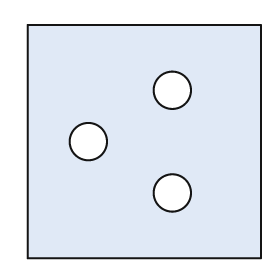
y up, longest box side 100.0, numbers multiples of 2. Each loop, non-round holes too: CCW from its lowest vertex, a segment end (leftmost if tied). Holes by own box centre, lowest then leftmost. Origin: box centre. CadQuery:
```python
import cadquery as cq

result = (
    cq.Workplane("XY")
    .moveTo(-50.0, -50.0)
    .lineTo(50.0, -50.0)
    .lineTo(50.0, 50.0)
    .lineTo(-50.0, 50.0)
    .close()
    .moveTo(12.0, -22.0)
    .circle(8.0)
    .moveTo(-24.0, 0.0)
    .circle(8.0)
    .moveTo(12.0, 22.0)
    .circle(8.0)
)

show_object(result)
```